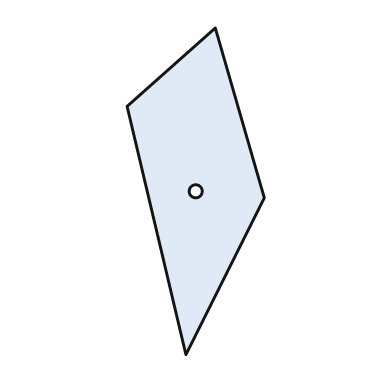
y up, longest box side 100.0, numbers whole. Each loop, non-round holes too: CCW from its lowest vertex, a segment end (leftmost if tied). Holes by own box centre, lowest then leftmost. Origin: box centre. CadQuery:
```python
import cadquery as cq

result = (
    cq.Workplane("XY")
    .moveTo(-3.0, -50.0)
    .lineTo(21.0, -2.0)
    .lineTo(6.0, 50.0)
    .lineTo(-21.0, 26.0)
    .close()
    .moveTo(0.0, 0.0)
    .circle(2.0)
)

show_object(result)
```